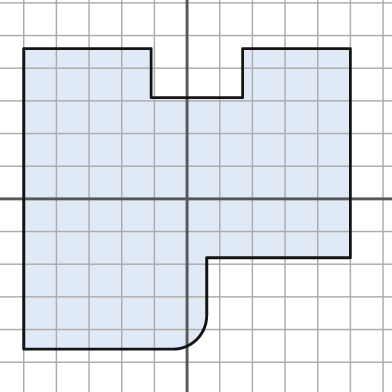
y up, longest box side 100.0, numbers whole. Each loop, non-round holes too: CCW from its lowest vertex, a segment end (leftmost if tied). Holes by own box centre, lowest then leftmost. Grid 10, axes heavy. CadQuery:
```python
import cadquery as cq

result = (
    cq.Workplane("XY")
    .moveTo(-50.0, -46.0)
    .lineTo(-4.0, -46.0)
    .threePointArc((3.0, -43.0), (6.0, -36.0))
    .lineTo(6.0, -18.0)
    .lineTo(50.0, -18.0)
    .lineTo(50.0, 46.0)
    .lineTo(17.0, 46.0)
    .lineTo(17.0, 31.0)
    .lineTo(-11.0, 31.0)
    .lineTo(-11.0, 46.0)
    .lineTo(-50.0, 46.0)
    .close()
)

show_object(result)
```